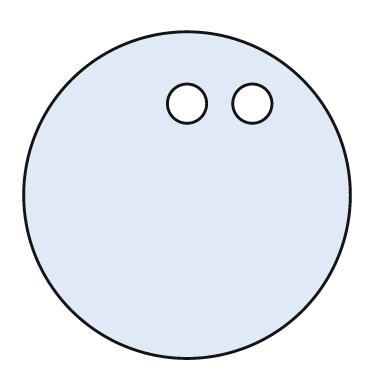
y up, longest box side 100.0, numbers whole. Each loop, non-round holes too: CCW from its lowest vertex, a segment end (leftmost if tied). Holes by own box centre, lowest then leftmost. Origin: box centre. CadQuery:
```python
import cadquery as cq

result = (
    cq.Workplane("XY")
    .moveTo(0.0, 0.0)
    .circle(50.0)
    .moveTo(0.0, 28.0)
    .circle(6.0)
    .moveTo(20.0, 28.0)
    .circle(6.0)
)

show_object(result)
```